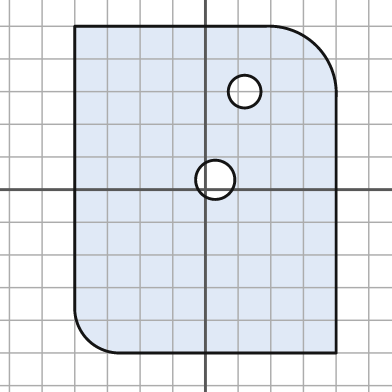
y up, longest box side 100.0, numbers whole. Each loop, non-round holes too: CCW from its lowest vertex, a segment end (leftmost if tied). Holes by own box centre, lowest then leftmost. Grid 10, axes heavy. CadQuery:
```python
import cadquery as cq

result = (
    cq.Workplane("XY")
    .moveTo(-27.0, -50.0)
    .lineTo(40.0, -50.0)
    .lineTo(40.0, 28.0)
    .threePointArc((34.0, 44.0), (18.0, 50.0))
    .lineTo(-40.0, 50.0)
    .lineTo(-40.0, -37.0)
    .threePointArc((-36.0, -46.0), (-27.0, -50.0))
    .close()
    .moveTo(3.0, 3.0)
    .circle(6.0)
    .moveTo(12.0, 30.0)
    .circle(5.0)
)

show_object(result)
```